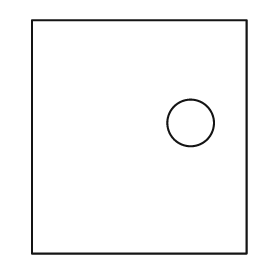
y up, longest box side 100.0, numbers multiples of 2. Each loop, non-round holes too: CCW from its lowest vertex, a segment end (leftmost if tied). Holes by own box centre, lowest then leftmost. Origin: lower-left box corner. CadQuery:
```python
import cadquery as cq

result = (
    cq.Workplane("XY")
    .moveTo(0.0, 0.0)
    .lineTo(92.0, 0.0)
    .lineTo(92.0, 100.0)
    .lineTo(0.0, 100.0)
    .close()
    .moveTo(68.0, 56.0)
    .circle(10.0)
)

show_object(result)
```